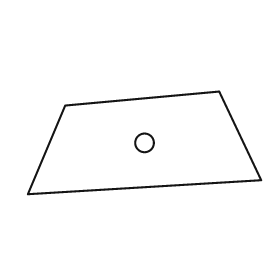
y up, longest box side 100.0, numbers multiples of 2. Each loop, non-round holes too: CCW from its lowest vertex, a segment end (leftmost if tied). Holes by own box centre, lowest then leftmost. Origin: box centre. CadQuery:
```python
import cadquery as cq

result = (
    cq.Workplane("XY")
    .moveTo(-50.0, -22.0)
    .lineTo(50.0, -16.0)
    .lineTo(32.0, 22.0)
    .lineTo(-34.0, 16.0)
    .close()
    .moveTo(0.0, 0.0)
    .circle(4.0)
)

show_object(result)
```